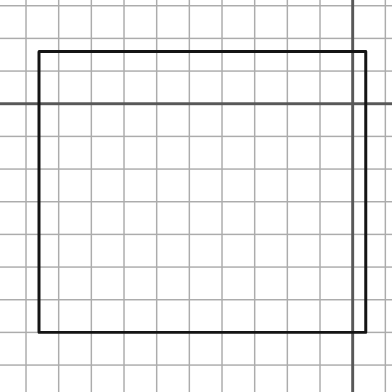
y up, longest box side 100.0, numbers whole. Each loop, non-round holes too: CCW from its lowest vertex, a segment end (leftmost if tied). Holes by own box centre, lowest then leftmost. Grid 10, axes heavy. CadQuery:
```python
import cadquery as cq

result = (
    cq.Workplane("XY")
    .moveTo(-96.0, -70.0)
    .lineTo(4.0, -70.0)
    .lineTo(4.0, 16.0)
    .lineTo(-96.0, 16.0)
    .close()
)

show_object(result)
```